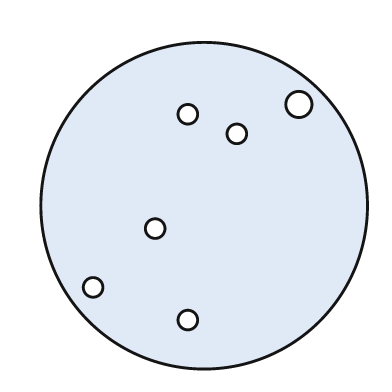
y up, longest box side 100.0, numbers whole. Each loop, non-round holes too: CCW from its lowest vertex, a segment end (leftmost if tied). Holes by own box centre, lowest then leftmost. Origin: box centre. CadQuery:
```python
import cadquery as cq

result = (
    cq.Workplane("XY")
    .moveTo(0.0, 0.0)
    .circle(50.0)
    .moveTo(-5.0, -35.0)
    .circle(3.0)
    .moveTo(-34.0, -25.0)
    .circle(3.0)
    .moveTo(-15.0, -7.0)
    .circle(3.0)
    .moveTo(10.0, 22.0)
    .circle(3.0)
    .moveTo(-5.0, 28.0)
    .circle(3.0)
    .moveTo(29.0, 31.0)
    .circle(4.0)
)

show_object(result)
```